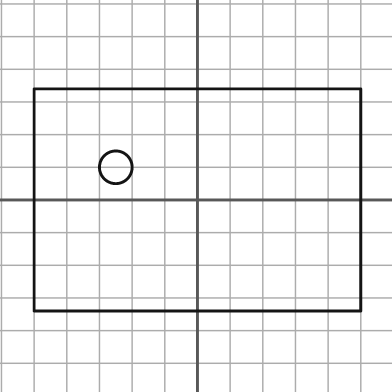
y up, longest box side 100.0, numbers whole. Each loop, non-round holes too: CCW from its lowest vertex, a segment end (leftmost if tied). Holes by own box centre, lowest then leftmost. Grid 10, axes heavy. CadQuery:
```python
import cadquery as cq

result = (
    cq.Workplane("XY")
    .moveTo(-50.0, -34.0)
    .lineTo(50.0, -34.0)
    .lineTo(50.0, 34.0)
    .lineTo(-50.0, 34.0)
    .close()
    .moveTo(-25.0, 10.0)
    .circle(5.0)
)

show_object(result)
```